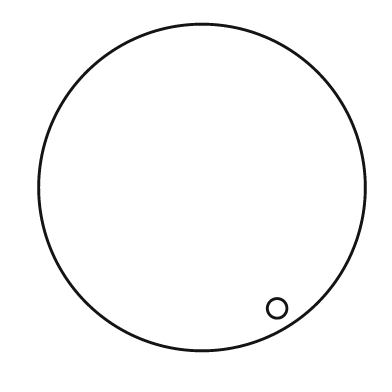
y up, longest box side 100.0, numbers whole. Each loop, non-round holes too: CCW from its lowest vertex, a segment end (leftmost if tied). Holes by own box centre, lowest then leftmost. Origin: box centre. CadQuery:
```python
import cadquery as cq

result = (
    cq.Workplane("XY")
    .moveTo(0.0, 0.0)
    .circle(50.0)
    .moveTo(23.0, -37.0)
    .circle(3.0)
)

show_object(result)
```